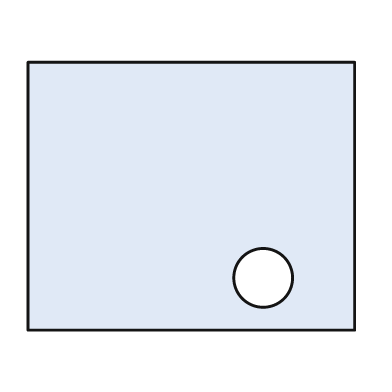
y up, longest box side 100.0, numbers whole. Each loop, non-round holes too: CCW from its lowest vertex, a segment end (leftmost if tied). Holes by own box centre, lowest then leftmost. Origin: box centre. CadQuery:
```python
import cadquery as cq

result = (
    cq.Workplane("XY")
    .moveTo(-50.0, -41.0)
    .lineTo(50.0, -41.0)
    .lineTo(50.0, 41.0)
    .lineTo(-50.0, 41.0)
    .close()
    .moveTo(22.0, -25.0)
    .circle(9.0)
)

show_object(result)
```